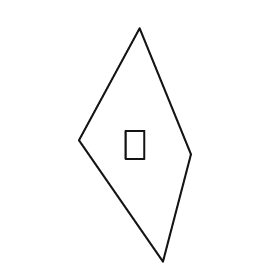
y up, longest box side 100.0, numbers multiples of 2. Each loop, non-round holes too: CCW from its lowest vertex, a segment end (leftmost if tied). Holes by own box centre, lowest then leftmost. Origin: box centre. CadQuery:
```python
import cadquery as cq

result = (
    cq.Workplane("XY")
    .moveTo(12.0, -50.0)
    .lineTo(24.0, -4.0)
    .lineTo(2.0, 50.0)
    .lineTo(-24.0, 2.0)
    .close()
    .moveTo(-4.0, -6.0)
    .lineTo(4.0, -6.0)
    .lineTo(4.0, 6.0)
    .lineTo(-4.0, 6.0)
    .close()
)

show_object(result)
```